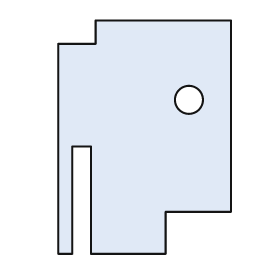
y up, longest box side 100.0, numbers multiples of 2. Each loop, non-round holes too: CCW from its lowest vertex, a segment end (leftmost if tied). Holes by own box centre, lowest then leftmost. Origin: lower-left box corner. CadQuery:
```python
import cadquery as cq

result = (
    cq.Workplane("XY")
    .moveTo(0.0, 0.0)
    .lineTo(6.0, 0.0)
    .lineTo(6.0, 46.0)
    .lineTo(14.0, 46.0)
    .lineTo(14.0, 0.0)
    .lineTo(46.0, 0.0)
    .lineTo(46.0, 18.0)
    .lineTo(74.0, 18.0)
    .lineTo(74.0, 100.0)
    .lineTo(16.0, 100.0)
    .lineTo(16.0, 90.0)
    .lineTo(0.0, 90.0)
    .close()
    .moveTo(56.0, 66.0)
    .circle(6.0)
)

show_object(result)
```